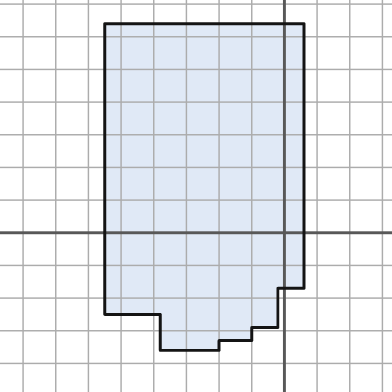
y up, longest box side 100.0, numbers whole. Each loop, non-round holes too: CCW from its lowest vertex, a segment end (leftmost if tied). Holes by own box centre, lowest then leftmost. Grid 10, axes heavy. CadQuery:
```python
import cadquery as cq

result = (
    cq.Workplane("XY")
    .moveTo(-38.0, -36.0)
    .lineTo(-20.0, -36.0)
    .lineTo(-20.0, -33.0)
    .lineTo(-10.0, -33.0)
    .lineTo(-10.0, -29.0)
    .lineTo(-2.0, -29.0)
    .lineTo(-2.0, -17.0)
    .lineTo(6.0, -17.0)
    .lineTo(6.0, 64.0)
    .lineTo(-55.0, 64.0)
    .lineTo(-55.0, -25.0)
    .lineTo(-38.0, -25.0)
    .close()
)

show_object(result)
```